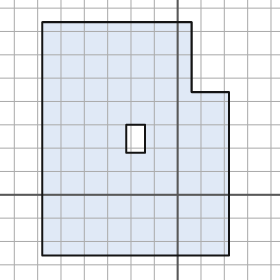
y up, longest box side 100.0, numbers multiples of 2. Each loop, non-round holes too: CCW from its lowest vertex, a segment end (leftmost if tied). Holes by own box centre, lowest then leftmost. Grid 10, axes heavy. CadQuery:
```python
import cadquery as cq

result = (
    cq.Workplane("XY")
    .moveTo(-58.0, -26.0)
    .lineTo(22.0, -26.0)
    .lineTo(22.0, 44.0)
    .lineTo(6.0, 44.0)
    .lineTo(6.0, 74.0)
    .lineTo(-58.0, 74.0)
    .close()
    .moveTo(-22.0, 18.0)
    .lineTo(-14.0, 18.0)
    .lineTo(-14.0, 30.0)
    .lineTo(-22.0, 30.0)
    .close()
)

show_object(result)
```